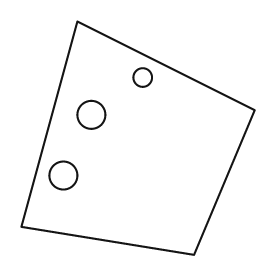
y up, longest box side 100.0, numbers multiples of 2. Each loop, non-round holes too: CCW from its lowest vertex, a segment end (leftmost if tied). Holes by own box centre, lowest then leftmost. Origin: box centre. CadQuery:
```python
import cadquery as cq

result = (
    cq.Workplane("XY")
    .moveTo(24.0, -50.0)
    .lineTo(50.0, 12.0)
    .lineTo(-26.0, 50.0)
    .lineTo(-50.0, -38.0)
    .close()
    .moveTo(-32.0, -16.0)
    .circle(6.0)
    .moveTo(-20.0, 10.0)
    .circle(6.0)
    .moveTo(2.0, 26.0)
    .circle(4.0)
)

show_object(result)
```